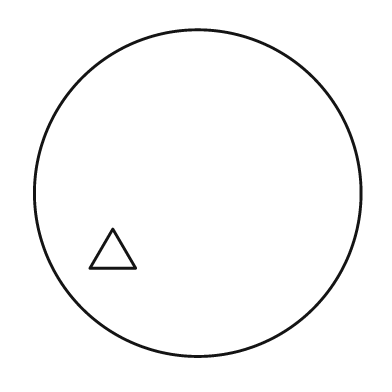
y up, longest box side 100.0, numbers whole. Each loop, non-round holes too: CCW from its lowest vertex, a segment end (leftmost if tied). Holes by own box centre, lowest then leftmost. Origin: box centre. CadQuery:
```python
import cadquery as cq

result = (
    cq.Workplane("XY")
    .moveTo(0.0, 0.0)
    .circle(50.0)
    .moveTo(-33.0, -23.0)
    .lineTo(-19.0, -23.0)
    .lineTo(-26.0, -11.0)
    .close()
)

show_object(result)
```